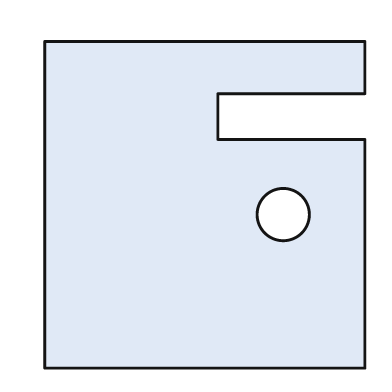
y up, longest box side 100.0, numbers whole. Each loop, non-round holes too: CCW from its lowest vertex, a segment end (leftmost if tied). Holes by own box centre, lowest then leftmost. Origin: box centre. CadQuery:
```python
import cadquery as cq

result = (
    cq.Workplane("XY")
    .moveTo(-49.0, -50.0)
    .lineTo(49.0, -50.0)
    .lineTo(49.0, 20.0)
    .lineTo(4.0, 20.0)
    .lineTo(4.0, 34.0)
    .lineTo(49.0, 34.0)
    .lineTo(49.0, 50.0)
    .lineTo(-49.0, 50.0)
    .close()
    .moveTo(24.0, -3.0)
    .circle(8.0)
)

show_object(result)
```